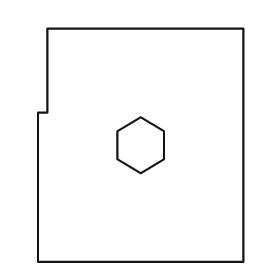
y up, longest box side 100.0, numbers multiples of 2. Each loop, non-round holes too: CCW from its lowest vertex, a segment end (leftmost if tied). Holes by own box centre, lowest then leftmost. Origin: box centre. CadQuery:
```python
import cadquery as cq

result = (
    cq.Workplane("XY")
    .moveTo(-44.0, -50.0)
    .lineTo(44.0, -50.0)
    .lineTo(44.0, 50.0)
    .lineTo(-40.0, 50.0)
    .lineTo(-40.0, 14.0)
    .lineTo(-44.0, 14.0)
    .close()
    .moveTo(0.0, -12.0)
    .lineTo(10.0, -6.0)
    .lineTo(10.0, 6.0)
    .lineTo(0.0, 12.0)
    .lineTo(-10.0, 6.0)
    .lineTo(-10.0, -6.0)
    .close()
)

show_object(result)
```